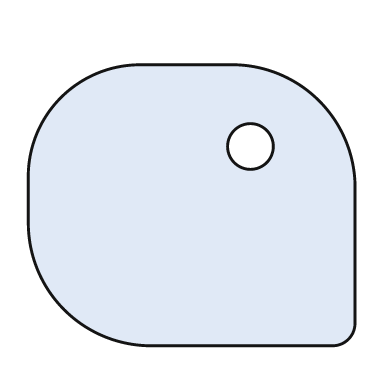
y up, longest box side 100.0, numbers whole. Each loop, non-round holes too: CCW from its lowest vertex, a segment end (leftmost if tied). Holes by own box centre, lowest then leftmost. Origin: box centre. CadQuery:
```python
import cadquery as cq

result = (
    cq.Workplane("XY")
    .moveTo(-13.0, -43.0)
    .lineTo(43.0, -43.0)
    .threePointArc((48.0, -41.0), (50.0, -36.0))
    .lineTo(50.0, 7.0)
    .threePointArc((39.0, 32.0), (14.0, 43.0))
    .lineTo(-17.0, 43.0)
    .threePointArc((-40.0, 33.0), (-50.0, 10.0))
    .lineTo(-50.0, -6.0)
    .threePointArc((-39.0, -32.0), (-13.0, -43.0))
    .close()
    .moveTo(18.0, 18.0)
    .circle(7.0)
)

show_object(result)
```